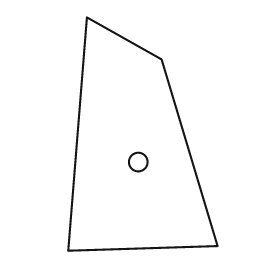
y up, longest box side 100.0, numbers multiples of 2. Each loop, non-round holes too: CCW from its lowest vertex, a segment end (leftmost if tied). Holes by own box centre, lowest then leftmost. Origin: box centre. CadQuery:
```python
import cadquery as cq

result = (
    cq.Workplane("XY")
    .moveTo(-32.0, -50.0)
    .lineTo(32.0, -48.0)
    .lineTo(8.0, 32.0)
    .lineTo(-24.0, 50.0)
    .close()
    .moveTo(-2.0, -12.0)
    .circle(4.0)
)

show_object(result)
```